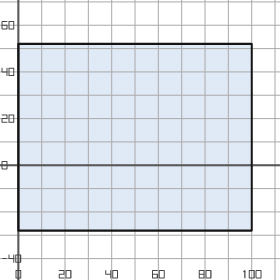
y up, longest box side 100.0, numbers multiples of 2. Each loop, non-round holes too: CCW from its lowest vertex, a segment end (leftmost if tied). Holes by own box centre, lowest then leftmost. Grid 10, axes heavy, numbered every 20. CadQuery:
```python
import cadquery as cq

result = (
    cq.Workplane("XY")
    .moveTo(0.0, -28.0)
    .lineTo(100.0, -28.0)
    .lineTo(100.0, 52.0)
    .lineTo(0.0, 52.0)
    .close()
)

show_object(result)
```